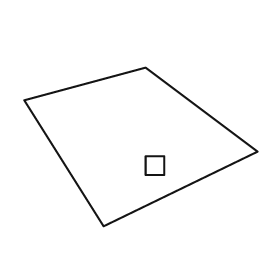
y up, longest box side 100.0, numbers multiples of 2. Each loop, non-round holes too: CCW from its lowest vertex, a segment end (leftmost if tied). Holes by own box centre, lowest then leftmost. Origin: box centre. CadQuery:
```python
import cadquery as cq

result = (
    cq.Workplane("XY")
    .moveTo(-16.0, -34.0)
    .lineTo(50.0, -2.0)
    .lineTo(2.0, 34.0)
    .lineTo(-50.0, 20.0)
    .close()
    .moveTo(2.0, -12.0)
    .lineTo(10.0, -12.0)
    .lineTo(10.0, -4.0)
    .lineTo(2.0, -4.0)
    .close()
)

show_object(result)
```